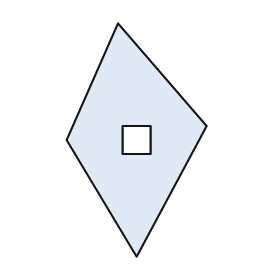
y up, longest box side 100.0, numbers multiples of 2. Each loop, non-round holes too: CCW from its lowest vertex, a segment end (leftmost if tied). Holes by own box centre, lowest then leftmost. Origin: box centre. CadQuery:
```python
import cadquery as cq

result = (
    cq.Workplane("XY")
    .moveTo(0.0, -50.0)
    .lineTo(30.0, 6.0)
    .lineTo(-8.0, 50.0)
    .lineTo(-30.0, 0.0)
    .close()
    .moveTo(-6.0, -6.0)
    .lineTo(6.0, -6.0)
    .lineTo(6.0, 6.0)
    .lineTo(-6.0, 6.0)
    .close()
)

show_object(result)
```